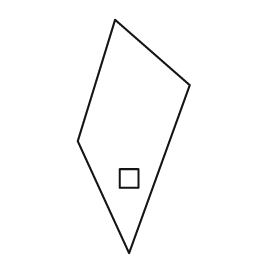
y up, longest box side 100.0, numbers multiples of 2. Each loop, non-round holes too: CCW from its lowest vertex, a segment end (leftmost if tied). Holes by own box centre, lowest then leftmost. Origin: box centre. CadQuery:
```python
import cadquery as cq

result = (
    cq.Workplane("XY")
    .moveTo(-2.0, -50.0)
    .lineTo(24.0, 22.0)
    .lineTo(-8.0, 50.0)
    .lineTo(-24.0, -2.0)
    .close()
    .moveTo(-6.0, -22.0)
    .lineTo(2.0, -22.0)
    .lineTo(2.0, -14.0)
    .lineTo(-6.0, -14.0)
    .close()
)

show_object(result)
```